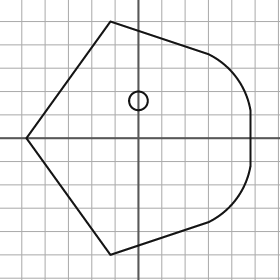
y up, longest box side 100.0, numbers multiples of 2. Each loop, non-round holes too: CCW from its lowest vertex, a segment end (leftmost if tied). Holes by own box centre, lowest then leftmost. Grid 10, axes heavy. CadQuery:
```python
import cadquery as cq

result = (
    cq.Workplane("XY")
    .moveTo(-12.0, -50.0)
    .lineTo(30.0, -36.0)
    .threePointArc((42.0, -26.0), (48.0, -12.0))
    .lineTo(48.0, 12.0)
    .threePointArc((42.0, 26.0), (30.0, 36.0))
    .lineTo(-12.0, 50.0)
    .lineTo(-48.0, 0.0)
    .close()
    .moveTo(0.0, 16.0)
    .circle(4.0)
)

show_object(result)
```